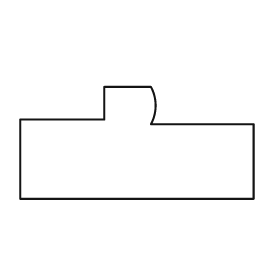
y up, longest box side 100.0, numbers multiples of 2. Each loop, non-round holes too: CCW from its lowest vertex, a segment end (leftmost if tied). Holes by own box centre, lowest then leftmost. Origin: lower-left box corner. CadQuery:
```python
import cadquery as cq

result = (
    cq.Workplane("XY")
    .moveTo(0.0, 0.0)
    .lineTo(100.0, 0.0)
    .lineTo(100.0, 32.0)
    .lineTo(56.0, 32.0)
    .threePointArc((58.0, 40.0), (56.0, 48.0))
    .lineTo(36.0, 48.0)
    .lineTo(36.0, 34.0)
    .lineTo(0.0, 34.0)
    .close()
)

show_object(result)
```